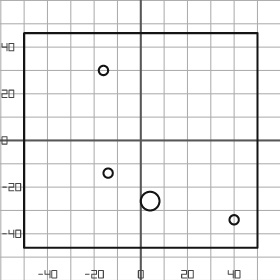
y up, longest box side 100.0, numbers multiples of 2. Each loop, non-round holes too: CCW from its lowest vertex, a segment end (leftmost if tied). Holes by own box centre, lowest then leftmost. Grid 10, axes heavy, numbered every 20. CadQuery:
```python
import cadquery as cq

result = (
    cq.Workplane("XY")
    .moveTo(-50.0, -46.0)
    .lineTo(50.0, -46.0)
    .lineTo(50.0, 46.0)
    .lineTo(-50.0, 46.0)
    .close()
    .moveTo(40.0, -34.0)
    .circle(2.0)
    .moveTo(4.0, -26.0)
    .circle(4.0)
    .moveTo(-14.0, -14.0)
    .circle(2.0)
    .moveTo(-16.0, 30.0)
    .circle(2.0)
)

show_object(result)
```